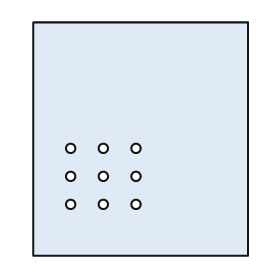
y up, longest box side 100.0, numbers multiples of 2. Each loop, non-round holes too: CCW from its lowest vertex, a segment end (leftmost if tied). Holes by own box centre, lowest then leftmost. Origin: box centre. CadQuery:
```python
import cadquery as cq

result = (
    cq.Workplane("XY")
    .moveTo(-46.0, -50.0)
    .lineTo(46.0, -50.0)
    .lineTo(46.0, 50.0)
    .lineTo(-46.0, 50.0)
    .close()
    .moveTo(-30.0, -28.0)
    .circle(2.0)
    .moveTo(-16.0, -28.0)
    .circle(2.0)
    .moveTo(-2.0, -28.0)
    .circle(2.0)
    .moveTo(-30.0, -16.0)
    .circle(2.0)
    .moveTo(-16.0, -16.0)
    .circle(2.0)
    .moveTo(-2.0, -16.0)
    .circle(2.0)
    .moveTo(-30.0, -4.0)
    .circle(2.0)
    .moveTo(-16.0, -4.0)
    .circle(2.0)
    .moveTo(-2.0, -4.0)
    .circle(2.0)
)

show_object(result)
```